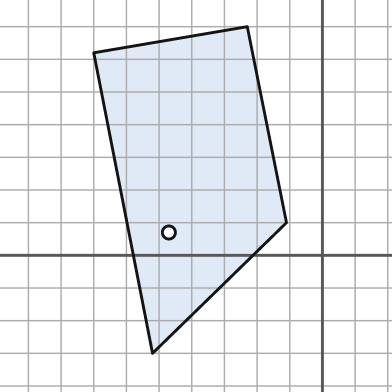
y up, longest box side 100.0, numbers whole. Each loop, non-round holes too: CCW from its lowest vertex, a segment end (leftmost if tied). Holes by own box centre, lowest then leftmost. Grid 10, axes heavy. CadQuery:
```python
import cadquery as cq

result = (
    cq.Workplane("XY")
    .moveTo(-52.0, -30.0)
    .lineTo(-11.0, 10.0)
    .lineTo(-23.0, 70.0)
    .lineTo(-70.0, 62.0)
    .close()
    .moveTo(-47.0, 7.0)
    .circle(2.0)
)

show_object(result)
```